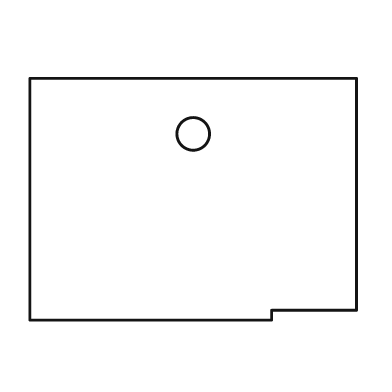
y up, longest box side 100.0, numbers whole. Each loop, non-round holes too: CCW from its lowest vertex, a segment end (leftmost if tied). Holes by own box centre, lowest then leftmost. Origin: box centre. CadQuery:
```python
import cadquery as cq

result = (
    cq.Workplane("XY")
    .moveTo(-50.0, -37.0)
    .lineTo(24.0, -37.0)
    .lineTo(24.0, -34.0)
    .lineTo(50.0, -34.0)
    .lineTo(50.0, 37.0)
    .lineTo(-50.0, 37.0)
    .close()
    .moveTo(0.0, 20.0)
    .circle(5.0)
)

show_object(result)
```